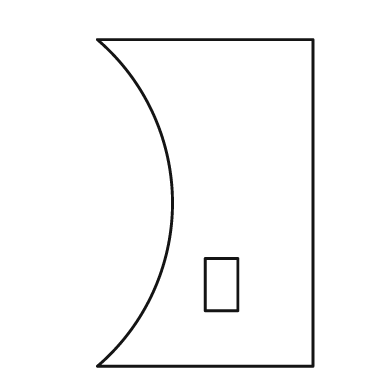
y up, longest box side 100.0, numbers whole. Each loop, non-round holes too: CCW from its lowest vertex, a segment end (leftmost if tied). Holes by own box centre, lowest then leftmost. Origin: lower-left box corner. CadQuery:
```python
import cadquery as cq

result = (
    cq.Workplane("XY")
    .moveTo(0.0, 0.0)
    .lineTo(66.0, 0.0)
    .lineTo(66.0, 100.0)
    .lineTo(0.0, 100.0)
    .threePointArc((23.0, 50.0), (0.0, 0.0))
    .close()
    .moveTo(33.0, 17.0)
    .lineTo(43.0, 17.0)
    .lineTo(43.0, 33.0)
    .lineTo(33.0, 33.0)
    .close()
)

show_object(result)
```